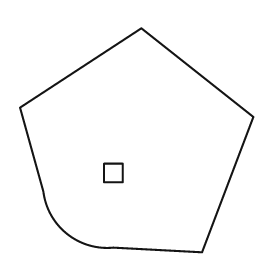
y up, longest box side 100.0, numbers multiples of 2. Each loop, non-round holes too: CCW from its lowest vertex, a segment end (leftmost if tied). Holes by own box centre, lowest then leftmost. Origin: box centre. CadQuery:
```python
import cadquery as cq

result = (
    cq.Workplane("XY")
    .moveTo(28.0, -48.0)
    .lineTo(50.0, 10.0)
    .lineTo(2.0, 48.0)
    .lineTo(-50.0, 14.0)
    .lineTo(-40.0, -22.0)
    .threePointArc((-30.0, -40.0), (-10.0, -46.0))
    .close()
    .moveTo(-14.0, -18.0)
    .lineTo(-6.0, -18.0)
    .lineTo(-6.0, -10.0)
    .lineTo(-14.0, -10.0)
    .close()
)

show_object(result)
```